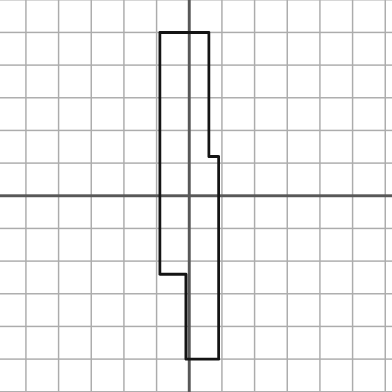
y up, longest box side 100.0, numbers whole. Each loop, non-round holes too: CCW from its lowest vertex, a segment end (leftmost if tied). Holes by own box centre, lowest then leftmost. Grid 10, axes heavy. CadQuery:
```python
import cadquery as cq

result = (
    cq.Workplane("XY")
    .moveTo(-1.0, -50.0)
    .lineTo(9.0, -50.0)
    .lineTo(9.0, 12.0)
    .lineTo(6.0, 12.0)
    .lineTo(6.0, 50.0)
    .lineTo(-9.0, 50.0)
    .lineTo(-9.0, -24.0)
    .lineTo(-1.0, -24.0)
    .close()
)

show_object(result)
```